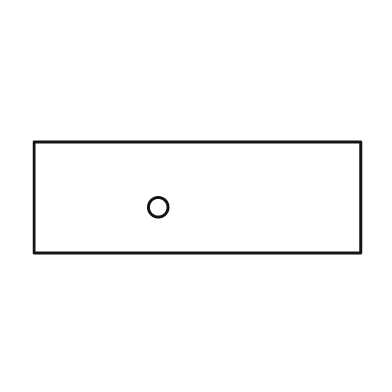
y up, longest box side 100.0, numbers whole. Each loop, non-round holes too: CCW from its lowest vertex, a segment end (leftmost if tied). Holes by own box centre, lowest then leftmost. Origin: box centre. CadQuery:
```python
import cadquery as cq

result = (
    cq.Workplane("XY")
    .moveTo(-50.0, -17.0)
    .lineTo(50.0, -17.0)
    .lineTo(50.0, 17.0)
    .lineTo(-50.0, 17.0)
    .close()
    .moveTo(-12.0, -3.0)
    .circle(3.0)
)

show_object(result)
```